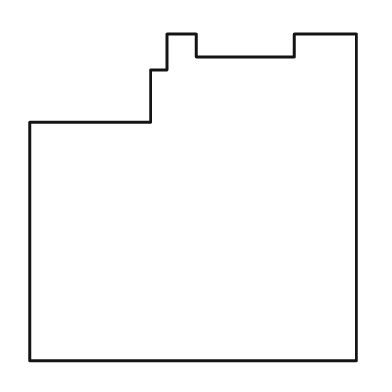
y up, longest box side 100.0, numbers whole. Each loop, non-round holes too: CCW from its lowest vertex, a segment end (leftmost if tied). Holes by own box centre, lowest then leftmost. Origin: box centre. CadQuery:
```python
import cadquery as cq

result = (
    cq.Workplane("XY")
    .moveTo(-50.0, -50.0)
    .lineTo(50.0, -50.0)
    .lineTo(50.0, 50.0)
    .lineTo(31.0, 50.0)
    .lineTo(31.0, 43.0)
    .lineTo(1.0, 43.0)
    .lineTo(1.0, 50.0)
    .lineTo(-8.0, 50.0)
    .lineTo(-8.0, 39.0)
    .lineTo(-13.0, 39.0)
    .lineTo(-13.0, 23.0)
    .lineTo(-50.0, 23.0)
    .close()
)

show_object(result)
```